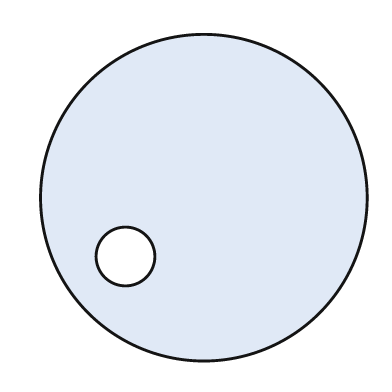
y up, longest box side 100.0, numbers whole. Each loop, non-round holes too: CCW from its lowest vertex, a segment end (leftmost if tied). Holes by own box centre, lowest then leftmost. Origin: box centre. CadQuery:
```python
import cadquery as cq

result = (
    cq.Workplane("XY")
    .moveTo(0.0, 0.0)
    .circle(50.0)
    .moveTo(-24.0, -18.0)
    .circle(9.0)
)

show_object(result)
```